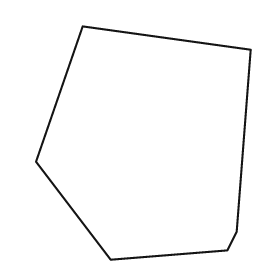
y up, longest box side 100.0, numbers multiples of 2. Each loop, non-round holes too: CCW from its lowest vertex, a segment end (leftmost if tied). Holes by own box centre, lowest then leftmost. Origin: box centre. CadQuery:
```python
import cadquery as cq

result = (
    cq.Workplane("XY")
    .moveTo(-14.0, -50.0)
    .lineTo(36.0, -46.0)
    .lineTo(40.0, -38.0)
    .lineTo(46.0, 40.0)
    .lineTo(-26.0, 50.0)
    .lineTo(-46.0, -8.0)
    .close()
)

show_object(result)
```